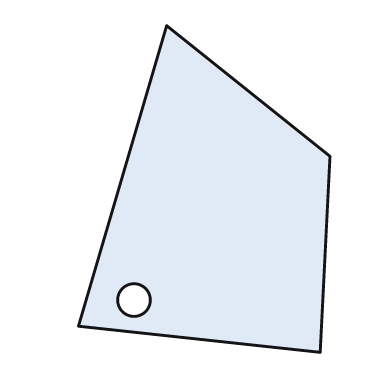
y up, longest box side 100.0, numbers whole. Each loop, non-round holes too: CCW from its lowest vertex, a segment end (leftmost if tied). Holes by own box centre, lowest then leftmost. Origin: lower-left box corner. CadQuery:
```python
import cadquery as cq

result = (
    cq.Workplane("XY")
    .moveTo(74.0, 0.0)
    .lineTo(77.0, 60.0)
    .lineTo(27.0, 100.0)
    .lineTo(0.0, 8.0)
    .close()
    .moveTo(17.0, 16.0)
    .circle(5.0)
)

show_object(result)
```